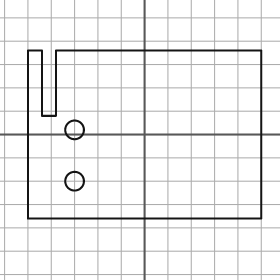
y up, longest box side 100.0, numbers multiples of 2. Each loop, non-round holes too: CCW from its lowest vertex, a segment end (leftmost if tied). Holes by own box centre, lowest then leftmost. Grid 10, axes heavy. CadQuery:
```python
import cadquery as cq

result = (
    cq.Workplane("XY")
    .moveTo(-50.0, -36.0)
    .lineTo(50.0, -36.0)
    .lineTo(50.0, 36.0)
    .lineTo(-38.0, 36.0)
    .lineTo(-38.0, 8.0)
    .lineTo(-44.0, 8.0)
    .lineTo(-44.0, 36.0)
    .lineTo(-50.0, 36.0)
    .close()
    .moveTo(-30.0, -20.0)
    .circle(4.0)
    .moveTo(-30.0, 2.0)
    .circle(4.0)
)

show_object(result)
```